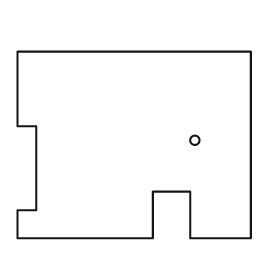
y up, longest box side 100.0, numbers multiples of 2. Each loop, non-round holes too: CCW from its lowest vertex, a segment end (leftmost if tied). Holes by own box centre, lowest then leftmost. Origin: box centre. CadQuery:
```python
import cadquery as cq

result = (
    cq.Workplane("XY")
    .moveTo(-50.0, -40.0)
    .lineTo(8.0, -40.0)
    .lineTo(8.0, -20.0)
    .lineTo(24.0, -20.0)
    .lineTo(24.0, -40.0)
    .lineTo(50.0, -40.0)
    .lineTo(50.0, 40.0)
    .lineTo(-50.0, 40.0)
    .lineTo(-50.0, 8.0)
    .lineTo(-42.0, 8.0)
    .lineTo(-42.0, -28.0)
    .lineTo(-50.0, -28.0)
    .close()
    .moveTo(26.0, 2.0)
    .circle(2.0)
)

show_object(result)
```